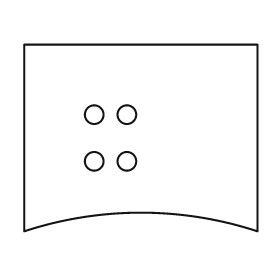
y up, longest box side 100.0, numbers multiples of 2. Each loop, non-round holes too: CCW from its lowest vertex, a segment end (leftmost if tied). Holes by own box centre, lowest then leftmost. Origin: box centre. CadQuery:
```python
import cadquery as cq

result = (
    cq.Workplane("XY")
    .moveTo(-50.0, -40.0)
    .threePointArc((0.0, -32.0), (50.0, -40.0))
    .lineTo(50.0, 40.0)
    .lineTo(-50.0, 40.0)
    .close()
    .moveTo(-20.0, -10.0)
    .circle(4.0)
    .moveTo(-6.0, -10.0)
    .circle(4.0)
    .moveTo(-20.0, 10.0)
    .circle(4.0)
    .moveTo(-6.0, 10.0)
    .circle(4.0)
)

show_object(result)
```